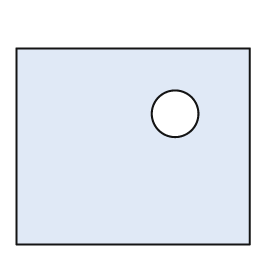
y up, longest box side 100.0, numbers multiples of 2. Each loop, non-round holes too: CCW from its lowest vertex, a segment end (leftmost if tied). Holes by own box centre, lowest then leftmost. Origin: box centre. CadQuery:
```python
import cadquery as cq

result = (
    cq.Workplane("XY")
    .moveTo(-50.0, -42.0)
    .lineTo(50.0, -42.0)
    .lineTo(50.0, 42.0)
    .lineTo(-50.0, 42.0)
    .close()
    .moveTo(18.0, 14.0)
    .circle(10.0)
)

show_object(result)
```